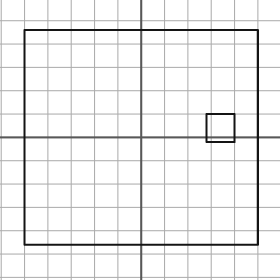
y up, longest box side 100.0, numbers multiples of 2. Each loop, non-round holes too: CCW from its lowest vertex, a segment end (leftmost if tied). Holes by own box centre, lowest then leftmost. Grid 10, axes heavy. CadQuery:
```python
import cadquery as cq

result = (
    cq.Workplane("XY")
    .moveTo(-50.0, -46.0)
    .lineTo(50.0, -46.0)
    .lineTo(50.0, 46.0)
    .lineTo(-50.0, 46.0)
    .close()
    .moveTo(28.0, -2.0)
    .lineTo(40.0, -2.0)
    .lineTo(40.0, 10.0)
    .lineTo(28.0, 10.0)
    .close()
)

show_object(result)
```